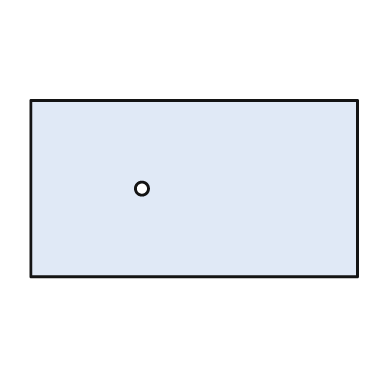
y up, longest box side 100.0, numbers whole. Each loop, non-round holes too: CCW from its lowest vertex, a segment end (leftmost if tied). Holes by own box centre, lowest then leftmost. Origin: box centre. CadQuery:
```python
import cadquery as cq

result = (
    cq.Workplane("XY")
    .moveTo(-50.0, -27.0)
    .lineTo(50.0, -27.0)
    .lineTo(50.0, 27.0)
    .lineTo(-50.0, 27.0)
    .close()
    .moveTo(-16.0, 0.0)
    .circle(2.0)
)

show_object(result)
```